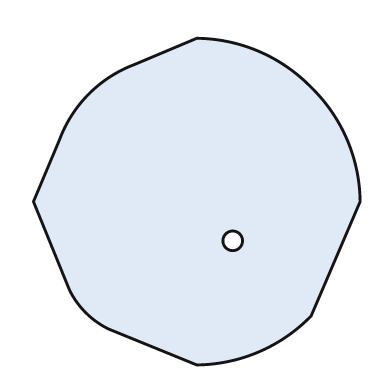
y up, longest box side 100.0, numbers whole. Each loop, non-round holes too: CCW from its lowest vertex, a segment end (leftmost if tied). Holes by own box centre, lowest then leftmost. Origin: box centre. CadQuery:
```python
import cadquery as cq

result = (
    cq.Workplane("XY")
    .moveTo(0.0, -50.0)
    .threePointArc((19.0, -46.0), (35.0, -35.0))
    .lineTo(50.0, 0.0)
    .threePointArc((46.0, 19.0), (35.0, 35.0))
    .threePointArc((19.0, 46.0), (0.0, 50.0))
    .lineTo(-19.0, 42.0)
    .threePointArc((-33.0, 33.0), (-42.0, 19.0))
    .lineTo(-50.0, 0.0)
    .lineTo(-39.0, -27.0)
    .threePointArc((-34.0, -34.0), (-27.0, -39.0))
    .close()
    .moveTo(11.0, -12.0)
    .circle(3.0)
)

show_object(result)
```